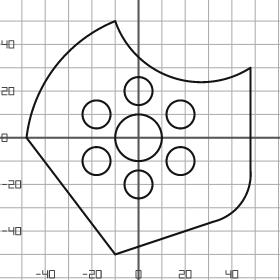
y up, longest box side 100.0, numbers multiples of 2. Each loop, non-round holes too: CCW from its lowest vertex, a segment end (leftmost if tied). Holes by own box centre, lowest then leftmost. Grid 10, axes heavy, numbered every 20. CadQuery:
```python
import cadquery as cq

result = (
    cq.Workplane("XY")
    .moveTo(-10.0, -50.0)
    .lineTo(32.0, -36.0)
    .threePointArc((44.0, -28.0), (48.0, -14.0))
    .lineTo(48.0, 30.0)
    .threePointArc((14.0, 26.0), (-10.0, 50.0))
    .threePointArc((-36.0, 30.0), (-48.0, 0.0))
    .close()
    .moveTo(0.0, -20.0)
    .circle(6.0)
    .moveTo(-18.0, -10.0)
    .circle(6.0)
    .moveTo(18.0, -10.0)
    .circle(6.0)
    .moveTo(0.0, 0.0)
    .circle(10.0)
    .moveTo(-18.0, 10.0)
    .circle(6.0)
    .moveTo(18.0, 10.0)
    .circle(6.0)
    .moveTo(0.0, 20.0)
    .circle(6.0)
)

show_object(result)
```